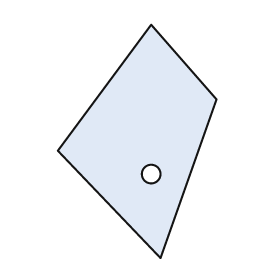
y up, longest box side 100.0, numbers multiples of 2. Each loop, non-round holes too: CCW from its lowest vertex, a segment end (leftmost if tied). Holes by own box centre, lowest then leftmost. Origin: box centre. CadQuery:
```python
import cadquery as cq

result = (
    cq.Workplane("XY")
    .moveTo(10.0, -50.0)
    .lineTo(34.0, 18.0)
    .lineTo(6.0, 50.0)
    .lineTo(-34.0, -4.0)
    .close()
    .moveTo(6.0, -14.0)
    .circle(4.0)
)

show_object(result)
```